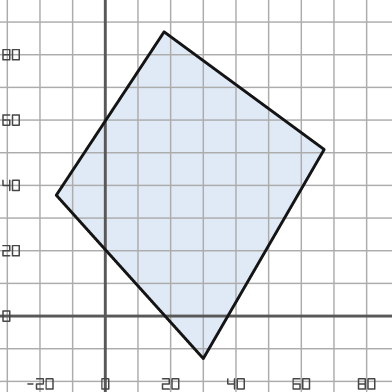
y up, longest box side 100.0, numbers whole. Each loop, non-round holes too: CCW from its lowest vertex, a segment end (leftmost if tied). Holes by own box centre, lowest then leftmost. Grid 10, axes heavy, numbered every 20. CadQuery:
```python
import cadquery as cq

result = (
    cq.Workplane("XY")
    .moveTo(30.0, -13.0)
    .lineTo(67.0, 51.0)
    .lineTo(18.0, 87.0)
    .lineTo(-15.0, 37.0)
    .close()
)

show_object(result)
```